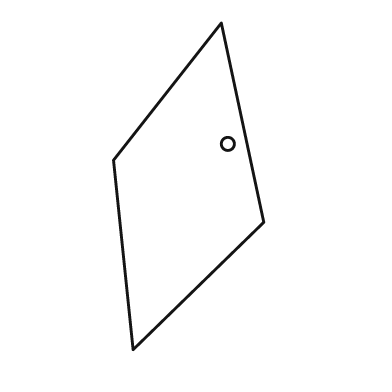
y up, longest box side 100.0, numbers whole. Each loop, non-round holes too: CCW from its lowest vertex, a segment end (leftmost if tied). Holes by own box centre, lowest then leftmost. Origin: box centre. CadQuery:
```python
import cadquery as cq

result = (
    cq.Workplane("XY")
    .moveTo(-17.0, -50.0)
    .lineTo(23.0, -11.0)
    .lineTo(10.0, 50.0)
    .lineTo(-23.0, 8.0)
    .close()
    .moveTo(12.0, 13.0)
    .circle(2.0)
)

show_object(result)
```